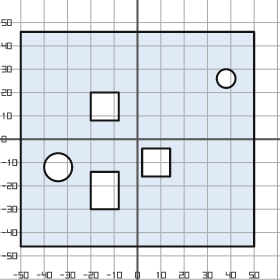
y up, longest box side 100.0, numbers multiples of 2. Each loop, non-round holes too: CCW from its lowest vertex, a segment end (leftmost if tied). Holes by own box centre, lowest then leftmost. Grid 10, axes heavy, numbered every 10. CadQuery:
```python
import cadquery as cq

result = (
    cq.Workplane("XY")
    .moveTo(-50.0, -46.0)
    .lineTo(50.0, -46.0)
    .lineTo(50.0, 46.0)
    .lineTo(-50.0, 46.0)
    .close()
    .moveTo(-20.0, -30.0)
    .lineTo(-8.0, -30.0)
    .lineTo(-8.0, -14.0)
    .lineTo(-20.0, -14.0)
    .close()
    .moveTo(-34.0, -12.0)
    .circle(6.0)
    .moveTo(2.0, -16.0)
    .lineTo(14.0, -16.0)
    .lineTo(14.0, -4.0)
    .lineTo(2.0, -4.0)
    .close()
    .moveTo(-20.0, 8.0)
    .lineTo(-8.0, 8.0)
    .lineTo(-8.0, 20.0)
    .lineTo(-20.0, 20.0)
    .close()
    .moveTo(38.0, 26.0)
    .circle(4.0)
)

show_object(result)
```